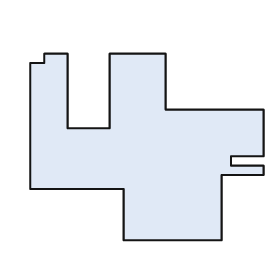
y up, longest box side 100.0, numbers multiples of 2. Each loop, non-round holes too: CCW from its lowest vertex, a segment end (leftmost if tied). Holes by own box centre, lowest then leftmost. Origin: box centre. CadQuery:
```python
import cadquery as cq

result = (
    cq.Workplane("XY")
    .moveTo(-10.0, -40.0)
    .lineTo(32.0, -40.0)
    .lineTo(32.0, -12.0)
    .lineTo(50.0, -12.0)
    .lineTo(50.0, -8.0)
    .lineTo(36.0, -8.0)
    .lineTo(36.0, -4.0)
    .lineTo(50.0, -4.0)
    .lineTo(50.0, 16.0)
    .lineTo(8.0, 16.0)
    .lineTo(8.0, 40.0)
    .lineTo(-16.0, 40.0)
    .lineTo(-16.0, 8.0)
    .lineTo(-34.0, 8.0)
    .lineTo(-34.0, 40.0)
    .lineTo(-44.0, 40.0)
    .lineTo(-44.0, 36.0)
    .lineTo(-50.0, 36.0)
    .lineTo(-50.0, -18.0)
    .lineTo(-10.0, -18.0)
    .close()
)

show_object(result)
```